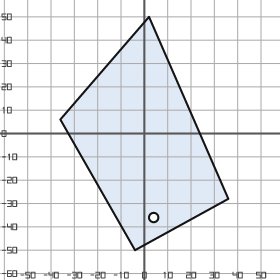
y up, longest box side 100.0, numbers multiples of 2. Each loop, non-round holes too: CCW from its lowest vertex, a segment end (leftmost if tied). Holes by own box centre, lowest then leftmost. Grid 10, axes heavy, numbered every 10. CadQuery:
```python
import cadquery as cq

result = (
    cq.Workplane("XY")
    .moveTo(-4.0, -50.0)
    .lineTo(36.0, -28.0)
    .lineTo(2.0, 50.0)
    .lineTo(-36.0, 6.0)
    .close()
    .moveTo(4.0, -36.0)
    .circle(2.0)
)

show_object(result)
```